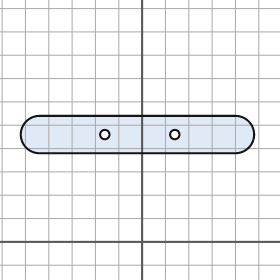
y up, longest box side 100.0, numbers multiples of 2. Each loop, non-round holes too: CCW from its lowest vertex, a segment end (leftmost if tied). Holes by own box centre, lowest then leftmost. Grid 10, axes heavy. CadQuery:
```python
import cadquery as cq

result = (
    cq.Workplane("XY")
    .moveTo(-44.0, 38.0)
    .lineTo(40.0, 38.0)
    .threePointArc((48.0, 46.0), (40.0, 54.0))
    .lineTo(-44.0, 54.0)
    .threePointArc((-52.0, 46.0), (-44.0, 38.0))
    .close()
    .moveTo(-16.0, 46.0)
    .circle(2.0)
    .moveTo(14.0, 46.0)
    .circle(2.0)
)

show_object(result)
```